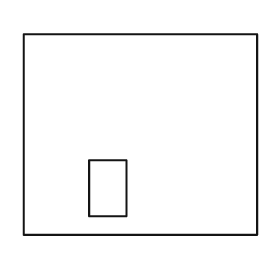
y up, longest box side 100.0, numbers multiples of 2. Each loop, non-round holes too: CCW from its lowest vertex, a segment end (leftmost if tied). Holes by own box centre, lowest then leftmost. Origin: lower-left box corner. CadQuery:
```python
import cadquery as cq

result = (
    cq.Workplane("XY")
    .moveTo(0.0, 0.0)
    .lineTo(100.0, 0.0)
    .lineTo(100.0, 86.0)
    .lineTo(0.0, 86.0)
    .close()
    .moveTo(28.0, 8.0)
    .lineTo(44.0, 8.0)
    .lineTo(44.0, 32.0)
    .lineTo(28.0, 32.0)
    .close()
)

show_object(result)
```